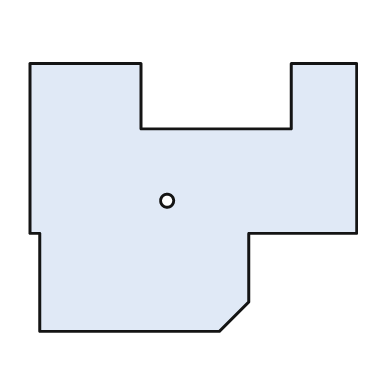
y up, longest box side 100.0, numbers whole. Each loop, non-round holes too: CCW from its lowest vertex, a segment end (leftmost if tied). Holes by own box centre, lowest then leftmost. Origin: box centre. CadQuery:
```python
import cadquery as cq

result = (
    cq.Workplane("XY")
    .moveTo(-47.0, -41.0)
    .lineTo(8.0, -41.0)
    .lineTo(17.0, -32.0)
    .lineTo(17.0, -11.0)
    .lineTo(50.0, -11.0)
    .lineTo(50.0, 41.0)
    .lineTo(30.0, 41.0)
    .lineTo(30.0, 21.0)
    .lineTo(-16.0, 21.0)
    .lineTo(-16.0, 41.0)
    .lineTo(-50.0, 41.0)
    .lineTo(-50.0, -11.0)
    .lineTo(-47.0, -11.0)
    .close()
    .moveTo(-8.0, -1.0)
    .circle(2.0)
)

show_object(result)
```